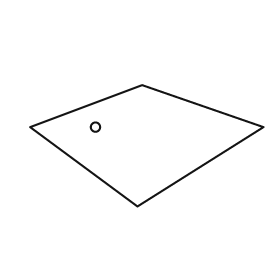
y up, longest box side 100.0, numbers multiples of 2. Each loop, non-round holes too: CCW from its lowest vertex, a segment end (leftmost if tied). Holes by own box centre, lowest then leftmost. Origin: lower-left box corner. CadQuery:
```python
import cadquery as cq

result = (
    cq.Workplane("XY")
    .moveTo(46.0, 0.0)
    .lineTo(100.0, 34.0)
    .lineTo(48.0, 52.0)
    .lineTo(0.0, 34.0)
    .close()
    .moveTo(28.0, 34.0)
    .circle(2.0)
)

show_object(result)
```